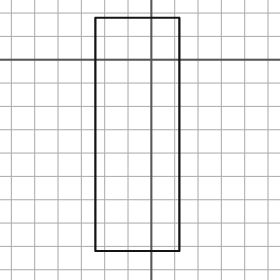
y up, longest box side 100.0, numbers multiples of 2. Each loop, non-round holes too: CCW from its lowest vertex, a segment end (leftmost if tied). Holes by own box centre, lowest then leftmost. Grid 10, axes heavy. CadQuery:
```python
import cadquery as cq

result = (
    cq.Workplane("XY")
    .moveTo(-24.0, -82.0)
    .lineTo(12.0, -82.0)
    .lineTo(12.0, 18.0)
    .lineTo(-24.0, 18.0)
    .close()
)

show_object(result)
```